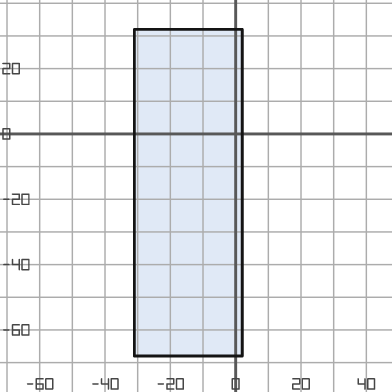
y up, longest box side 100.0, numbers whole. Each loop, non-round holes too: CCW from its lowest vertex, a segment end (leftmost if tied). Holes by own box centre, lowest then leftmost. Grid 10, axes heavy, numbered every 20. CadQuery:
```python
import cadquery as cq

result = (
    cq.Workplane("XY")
    .moveTo(-31.0, -68.0)
    .lineTo(2.0, -68.0)
    .lineTo(2.0, 32.0)
    .lineTo(-31.0, 32.0)
    .close()
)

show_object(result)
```